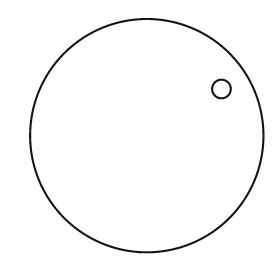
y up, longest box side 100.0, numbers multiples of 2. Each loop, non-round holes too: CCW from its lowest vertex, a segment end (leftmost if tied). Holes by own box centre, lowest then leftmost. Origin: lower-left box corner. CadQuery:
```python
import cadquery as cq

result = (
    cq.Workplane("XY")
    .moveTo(50.0, 50.0)
    .circle(50.0)
    .moveTo(82.0, 70.0)
    .circle(4.0)
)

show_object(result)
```